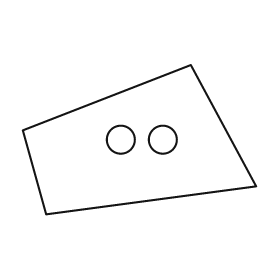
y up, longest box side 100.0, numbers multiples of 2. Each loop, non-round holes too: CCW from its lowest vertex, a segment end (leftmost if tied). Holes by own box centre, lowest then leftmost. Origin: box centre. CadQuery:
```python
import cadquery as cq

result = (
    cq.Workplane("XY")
    .moveTo(-40.0, -32.0)
    .lineTo(50.0, -20.0)
    .lineTo(22.0, 32.0)
    .lineTo(-50.0, 4.0)
    .close()
    .moveTo(-8.0, 0.0)
    .circle(6.0)
    .moveTo(10.0, 0.0)
    .circle(6.0)
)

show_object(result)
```